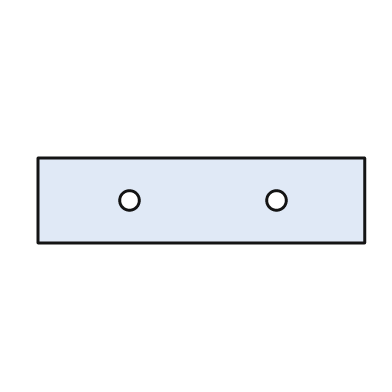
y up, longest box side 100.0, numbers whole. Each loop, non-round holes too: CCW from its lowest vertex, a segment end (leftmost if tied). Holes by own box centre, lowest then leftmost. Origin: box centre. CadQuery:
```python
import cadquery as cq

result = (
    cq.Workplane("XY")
    .moveTo(-50.0, -13.0)
    .lineTo(50.0, -13.0)
    .lineTo(50.0, 13.0)
    .lineTo(-50.0, 13.0)
    .close()
    .moveTo(-22.0, 0.0)
    .circle(3.0)
    .moveTo(23.0, 0.0)
    .circle(3.0)
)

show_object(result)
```